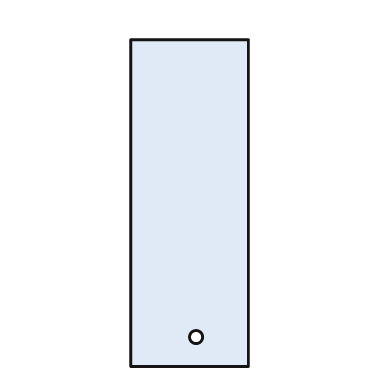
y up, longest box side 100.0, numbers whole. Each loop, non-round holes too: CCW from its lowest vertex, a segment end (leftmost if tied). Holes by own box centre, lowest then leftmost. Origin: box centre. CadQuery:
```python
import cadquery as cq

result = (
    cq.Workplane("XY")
    .moveTo(-18.0, -50.0)
    .lineTo(18.0, -50.0)
    .lineTo(18.0, 50.0)
    .lineTo(-18.0, 50.0)
    .close()
    .moveTo(2.0, -41.0)
    .circle(2.0)
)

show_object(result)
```